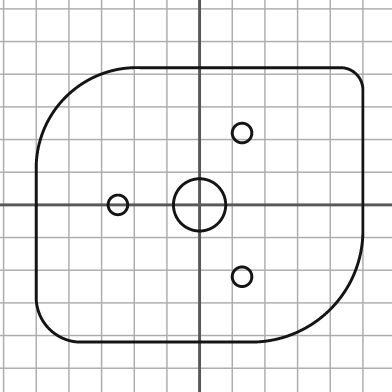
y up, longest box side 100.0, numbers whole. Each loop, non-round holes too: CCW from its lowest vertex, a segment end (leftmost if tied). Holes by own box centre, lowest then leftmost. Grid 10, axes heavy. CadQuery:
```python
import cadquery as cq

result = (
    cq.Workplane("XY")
    .moveTo(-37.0, -42.0)
    .lineTo(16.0, -42.0)
    .threePointArc((40.0, -32.0), (50.0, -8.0))
    .lineTo(50.0, 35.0)
    .threePointArc((48.0, 40.0), (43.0, 42.0))
    .lineTo(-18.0, 42.0)
    .threePointArc((-41.0, 33.0), (-50.0, 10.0))
    .lineTo(-50.0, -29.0)
    .threePointArc((-46.0, -38.0), (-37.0, -42.0))
    .close()
    .moveTo(13.0, -22.0)
    .circle(3.0)
    .moveTo(-25.0, 0.0)
    .circle(3.0)
    .moveTo(0.0, 0.0)
    .circle(8.0)
    .moveTo(13.0, 22.0)
    .circle(3.0)
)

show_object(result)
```